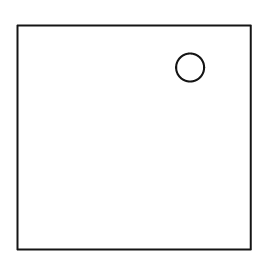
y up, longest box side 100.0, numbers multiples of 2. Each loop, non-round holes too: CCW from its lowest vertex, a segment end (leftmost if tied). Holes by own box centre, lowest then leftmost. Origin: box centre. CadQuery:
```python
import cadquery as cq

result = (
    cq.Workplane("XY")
    .moveTo(-50.0, -48.0)
    .lineTo(50.0, -48.0)
    .lineTo(50.0, 48.0)
    .lineTo(-50.0, 48.0)
    .close()
    .moveTo(24.0, 30.0)
    .circle(6.0)
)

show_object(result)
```